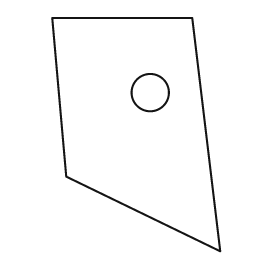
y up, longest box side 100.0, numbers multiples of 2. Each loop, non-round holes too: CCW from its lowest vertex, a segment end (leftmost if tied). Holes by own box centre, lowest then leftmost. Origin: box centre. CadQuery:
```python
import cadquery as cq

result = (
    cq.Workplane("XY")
    .moveTo(36.0, -50.0)
    .lineTo(24.0, 50.0)
    .lineTo(-36.0, 50.0)
    .lineTo(-30.0, -18.0)
    .close()
    .moveTo(6.0, 18.0)
    .circle(8.0)
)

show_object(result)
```